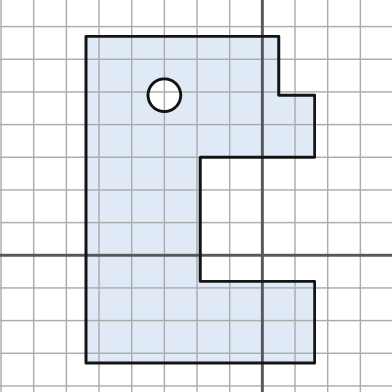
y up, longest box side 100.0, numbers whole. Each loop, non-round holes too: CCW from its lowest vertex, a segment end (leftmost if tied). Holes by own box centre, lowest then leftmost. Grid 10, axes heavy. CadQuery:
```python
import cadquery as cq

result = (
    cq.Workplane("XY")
    .moveTo(-54.0, -33.0)
    .lineTo(16.0, -33.0)
    .lineTo(16.0, -8.0)
    .lineTo(-19.0, -8.0)
    .lineTo(-19.0, 30.0)
    .lineTo(16.0, 30.0)
    .lineTo(16.0, 49.0)
    .lineTo(5.0, 49.0)
    .lineTo(5.0, 67.0)
    .lineTo(-54.0, 67.0)
    .close()
    .moveTo(-30.0, 49.0)
    .circle(5.0)
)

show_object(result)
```